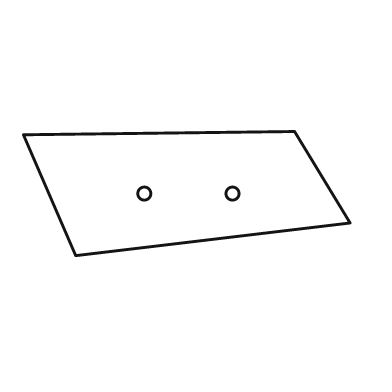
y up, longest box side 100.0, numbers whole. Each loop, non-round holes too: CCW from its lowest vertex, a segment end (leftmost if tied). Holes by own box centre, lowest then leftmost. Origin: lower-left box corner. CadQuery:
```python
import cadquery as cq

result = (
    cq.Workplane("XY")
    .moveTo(16.0, 0.0)
    .lineTo(100.0, 10.0)
    .lineTo(83.0, 38.0)
    .lineTo(0.0, 37.0)
    .close()
    .moveTo(37.0, 19.0)
    .circle(2.0)
    .moveTo(64.0, 19.0)
    .circle(2.0)
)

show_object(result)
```